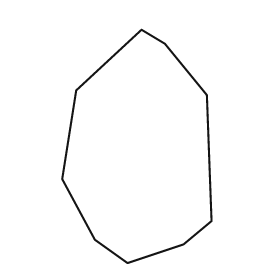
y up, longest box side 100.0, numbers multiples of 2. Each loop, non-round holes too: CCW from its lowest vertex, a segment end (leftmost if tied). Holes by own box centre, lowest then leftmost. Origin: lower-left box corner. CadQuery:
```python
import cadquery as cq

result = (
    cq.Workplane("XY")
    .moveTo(28.0, 0.0)
    .lineTo(52.0, 8.0)
    .lineTo(64.0, 18.0)
    .lineTo(62.0, 72.0)
    .lineTo(44.0, 94.0)
    .lineTo(34.0, 100.0)
    .lineTo(6.0, 74.0)
    .lineTo(0.0, 36.0)
    .lineTo(14.0, 10.0)
    .close()
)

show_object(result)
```